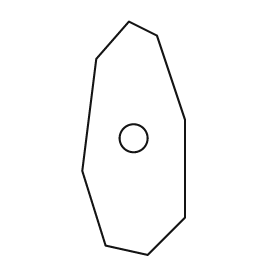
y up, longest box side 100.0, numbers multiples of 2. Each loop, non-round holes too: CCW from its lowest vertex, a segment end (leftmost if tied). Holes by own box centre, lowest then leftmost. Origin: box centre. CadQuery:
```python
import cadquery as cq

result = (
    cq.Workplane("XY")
    .moveTo(6.0, -50.0)
    .lineTo(22.0, -34.0)
    .lineTo(22.0, 8.0)
    .lineTo(10.0, 44.0)
    .lineTo(-2.0, 50.0)
    .lineTo(-16.0, 34.0)
    .lineTo(-22.0, -14.0)
    .lineTo(-12.0, -46.0)
    .close()
    .moveTo(0.0, 0.0)
    .circle(6.0)
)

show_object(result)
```